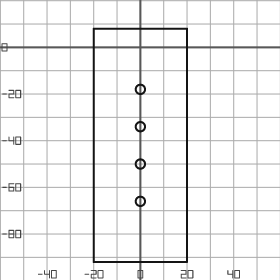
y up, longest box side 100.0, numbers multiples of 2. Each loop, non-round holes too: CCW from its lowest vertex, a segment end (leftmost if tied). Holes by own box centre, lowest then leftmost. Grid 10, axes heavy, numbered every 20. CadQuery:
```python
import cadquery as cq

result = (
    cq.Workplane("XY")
    .moveTo(-20.0, -92.0)
    .lineTo(20.0, -92.0)
    .lineTo(20.0, 8.0)
    .lineTo(-20.0, 8.0)
    .close()
    .moveTo(0.0, -66.0)
    .circle(2.0)
    .moveTo(0.0, -50.0)
    .circle(2.0)
    .moveTo(0.0, -34.0)
    .circle(2.0)
    .moveTo(0.0, -18.0)
    .circle(2.0)
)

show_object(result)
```